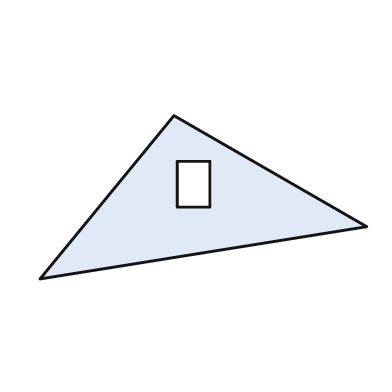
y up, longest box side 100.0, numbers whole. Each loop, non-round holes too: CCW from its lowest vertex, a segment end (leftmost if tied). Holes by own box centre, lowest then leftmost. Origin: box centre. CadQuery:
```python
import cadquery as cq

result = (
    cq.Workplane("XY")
    .moveTo(-50.0, -25.0)
    .lineTo(50.0, -9.0)
    .lineTo(-9.0, 25.0)
    .close()
    .moveTo(-8.0, -3.0)
    .lineTo(2.0, -3.0)
    .lineTo(2.0, 11.0)
    .lineTo(-8.0, 11.0)
    .close()
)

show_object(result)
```